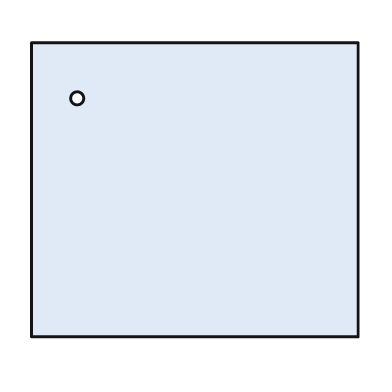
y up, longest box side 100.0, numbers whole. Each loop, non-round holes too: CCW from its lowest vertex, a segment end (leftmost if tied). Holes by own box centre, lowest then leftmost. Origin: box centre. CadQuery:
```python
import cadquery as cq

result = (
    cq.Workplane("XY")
    .moveTo(-50.0, -45.0)
    .lineTo(50.0, -45.0)
    .lineTo(50.0, 45.0)
    .lineTo(-50.0, 45.0)
    .close()
    .moveTo(-36.0, 28.0)
    .circle(2.0)
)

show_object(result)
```